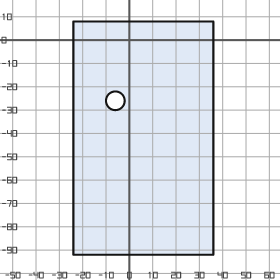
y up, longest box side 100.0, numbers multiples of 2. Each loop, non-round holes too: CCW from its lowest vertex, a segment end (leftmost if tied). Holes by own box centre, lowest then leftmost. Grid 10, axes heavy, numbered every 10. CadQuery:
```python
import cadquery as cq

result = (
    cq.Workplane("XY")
    .moveTo(-24.0, -92.0)
    .lineTo(36.0, -92.0)
    .lineTo(36.0, 8.0)
    .lineTo(-24.0, 8.0)
    .close()
    .moveTo(-6.0, -26.0)
    .circle(4.0)
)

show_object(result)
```